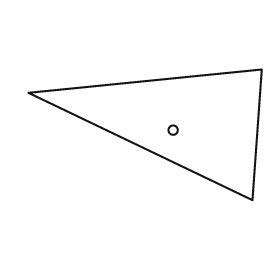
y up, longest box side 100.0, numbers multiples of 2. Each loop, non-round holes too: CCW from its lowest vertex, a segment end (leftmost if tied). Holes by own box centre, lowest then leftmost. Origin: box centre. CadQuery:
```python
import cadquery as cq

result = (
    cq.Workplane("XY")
    .moveTo(46.0, -28.0)
    .lineTo(50.0, 28.0)
    .lineTo(-50.0, 18.0)
    .close()
    .moveTo(12.0, 2.0)
    .circle(2.0)
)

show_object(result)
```